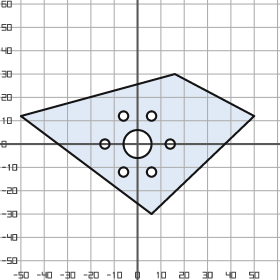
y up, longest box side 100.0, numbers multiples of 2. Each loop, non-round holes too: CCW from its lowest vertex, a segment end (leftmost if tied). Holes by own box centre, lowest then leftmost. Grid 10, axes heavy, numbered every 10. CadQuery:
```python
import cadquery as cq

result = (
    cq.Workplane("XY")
    .moveTo(6.0, -30.0)
    .lineTo(50.0, 12.0)
    .lineTo(16.0, 30.0)
    .lineTo(-50.0, 12.0)
    .close()
    .moveTo(-6.0, -12.0)
    .circle(2.0)
    .moveTo(6.0, -12.0)
    .circle(2.0)
    .moveTo(-14.0, 0.0)
    .circle(2.0)
    .moveTo(0.0, 0.0)
    .circle(6.0)
    .moveTo(14.0, 0.0)
    .circle(2.0)
    .moveTo(-6.0, 12.0)
    .circle(2.0)
    .moveTo(6.0, 12.0)
    .circle(2.0)
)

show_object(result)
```